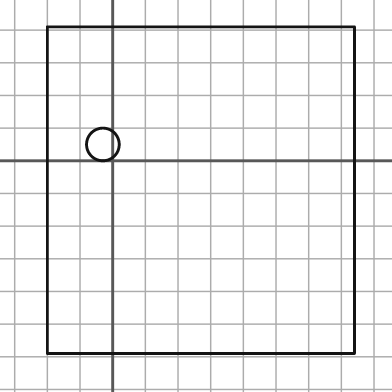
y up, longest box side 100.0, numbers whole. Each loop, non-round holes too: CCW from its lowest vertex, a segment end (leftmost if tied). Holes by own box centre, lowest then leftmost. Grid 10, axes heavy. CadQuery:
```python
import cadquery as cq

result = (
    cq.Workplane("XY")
    .moveTo(-20.0, -59.0)
    .lineTo(74.0, -59.0)
    .lineTo(74.0, 41.0)
    .lineTo(-20.0, 41.0)
    .close()
    .moveTo(-3.0, 5.0)
    .circle(5.0)
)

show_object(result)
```